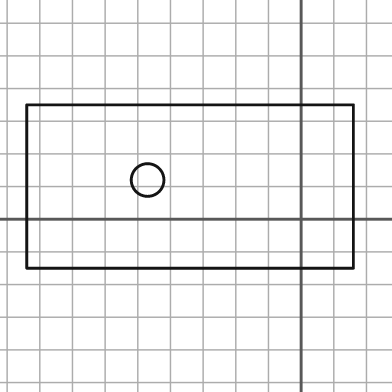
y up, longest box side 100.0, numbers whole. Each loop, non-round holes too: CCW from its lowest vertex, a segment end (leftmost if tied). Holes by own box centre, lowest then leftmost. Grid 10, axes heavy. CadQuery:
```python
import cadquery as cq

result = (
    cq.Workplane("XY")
    .moveTo(-84.0, -15.0)
    .lineTo(16.0, -15.0)
    .lineTo(16.0, 35.0)
    .lineTo(-84.0, 35.0)
    .close()
    .moveTo(-47.0, 12.0)
    .circle(5.0)
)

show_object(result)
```